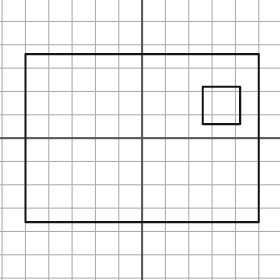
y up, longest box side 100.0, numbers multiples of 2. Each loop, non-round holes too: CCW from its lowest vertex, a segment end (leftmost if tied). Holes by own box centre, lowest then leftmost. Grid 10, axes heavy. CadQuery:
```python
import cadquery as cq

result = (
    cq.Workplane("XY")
    .moveTo(-50.0, -36.0)
    .lineTo(50.0, -36.0)
    .lineTo(50.0, 36.0)
    .lineTo(-50.0, 36.0)
    .close()
    .moveTo(26.0, 6.0)
    .lineTo(42.0, 6.0)
    .lineTo(42.0, 22.0)
    .lineTo(26.0, 22.0)
    .close()
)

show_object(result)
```